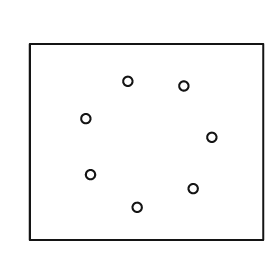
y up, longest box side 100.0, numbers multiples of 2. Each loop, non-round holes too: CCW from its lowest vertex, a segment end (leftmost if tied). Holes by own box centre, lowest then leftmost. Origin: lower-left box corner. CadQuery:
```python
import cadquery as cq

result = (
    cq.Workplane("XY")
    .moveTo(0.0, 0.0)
    .lineTo(100.0, 0.0)
    .lineTo(100.0, 84.0)
    .lineTo(0.0, 84.0)
    .close()
    .moveTo(46.0, 14.0)
    .circle(2.0)
    .moveTo(70.0, 22.0)
    .circle(2.0)
    .moveTo(26.0, 28.0)
    .circle(2.0)
    .moveTo(78.0, 44.0)
    .circle(2.0)
    .moveTo(24.0, 52.0)
    .circle(2.0)
    .moveTo(66.0, 66.0)
    .circle(2.0)
    .moveTo(42.0, 68.0)
    .circle(2.0)
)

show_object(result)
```